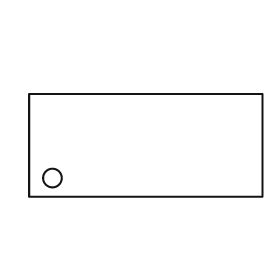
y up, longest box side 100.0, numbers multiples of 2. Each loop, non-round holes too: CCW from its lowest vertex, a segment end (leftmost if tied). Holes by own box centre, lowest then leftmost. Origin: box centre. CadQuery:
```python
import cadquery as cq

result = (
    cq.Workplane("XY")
    .moveTo(-50.0, -22.0)
    .lineTo(50.0, -22.0)
    .lineTo(50.0, 22.0)
    .lineTo(-50.0, 22.0)
    .close()
    .moveTo(-40.0, -14.0)
    .circle(4.0)
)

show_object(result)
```